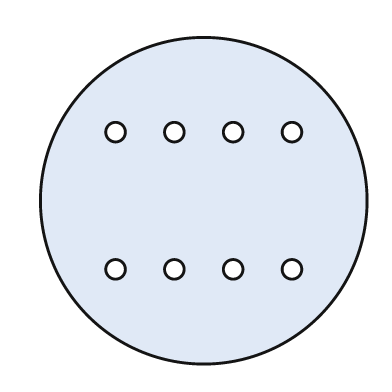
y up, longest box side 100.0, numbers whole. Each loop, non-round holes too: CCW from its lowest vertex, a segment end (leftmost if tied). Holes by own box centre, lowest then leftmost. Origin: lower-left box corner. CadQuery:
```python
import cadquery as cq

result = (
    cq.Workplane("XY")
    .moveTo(50.0, 50.0)
    .circle(50.0)
    .moveTo(23.0, 29.0)
    .circle(3.0)
    .moveTo(41.0, 29.0)
    .circle(3.0)
    .moveTo(59.0, 29.0)
    .circle(3.0)
    .moveTo(77.0, 29.0)
    .circle(3.0)
    .moveTo(23.0, 71.0)
    .circle(3.0)
    .moveTo(41.0, 71.0)
    .circle(3.0)
    .moveTo(59.0, 71.0)
    .circle(3.0)
    .moveTo(77.0, 71.0)
    .circle(3.0)
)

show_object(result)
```